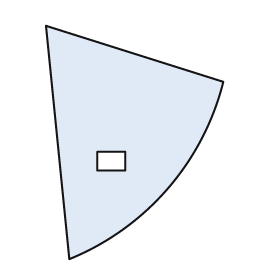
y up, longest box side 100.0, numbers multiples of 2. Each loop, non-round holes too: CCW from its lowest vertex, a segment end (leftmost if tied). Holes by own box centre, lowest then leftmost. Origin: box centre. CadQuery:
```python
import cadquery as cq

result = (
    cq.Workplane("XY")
    .moveTo(-28.0, -50.0)
    .threePointArc((14.0, -20.0), (38.0, 26.0))
    .lineTo(-38.0, 50.0)
    .close()
    .moveTo(-16.0, -12.0)
    .lineTo(-4.0, -12.0)
    .lineTo(-4.0, -4.0)
    .lineTo(-16.0, -4.0)
    .close()
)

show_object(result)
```